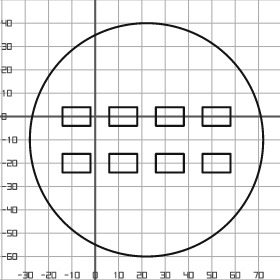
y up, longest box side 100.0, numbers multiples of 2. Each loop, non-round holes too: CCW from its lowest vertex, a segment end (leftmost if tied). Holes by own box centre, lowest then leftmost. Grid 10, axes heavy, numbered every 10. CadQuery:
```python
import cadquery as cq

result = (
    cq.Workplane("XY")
    .moveTo(22.0, -10.0)
    .circle(50.0)
    .moveTo(-14.0, -24.0)
    .lineTo(-2.0, -24.0)
    .lineTo(-2.0, -16.0)
    .lineTo(-14.0, -16.0)
    .close()
    .moveTo(6.0, -24.0)
    .lineTo(18.0, -24.0)
    .lineTo(18.0, -16.0)
    .lineTo(6.0, -16.0)
    .close()
    .moveTo(26.0, -24.0)
    .lineTo(38.0, -24.0)
    .lineTo(38.0, -16.0)
    .lineTo(26.0, -16.0)
    .close()
    .moveTo(46.0, -24.0)
    .lineTo(58.0, -24.0)
    .lineTo(58.0, -16.0)
    .lineTo(46.0, -16.0)
    .close()
    .moveTo(-14.0, -4.0)
    .lineTo(-2.0, -4.0)
    .lineTo(-2.0, 4.0)
    .lineTo(-14.0, 4.0)
    .close()
    .moveTo(6.0, -4.0)
    .lineTo(18.0, -4.0)
    .lineTo(18.0, 4.0)
    .lineTo(6.0, 4.0)
    .close()
    .moveTo(26.0, -4.0)
    .lineTo(38.0, -4.0)
    .lineTo(38.0, 4.0)
    .lineTo(26.0, 4.0)
    .close()
    .moveTo(46.0, -4.0)
    .lineTo(58.0, -4.0)
    .lineTo(58.0, 4.0)
    .lineTo(46.0, 4.0)
    .close()
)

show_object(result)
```